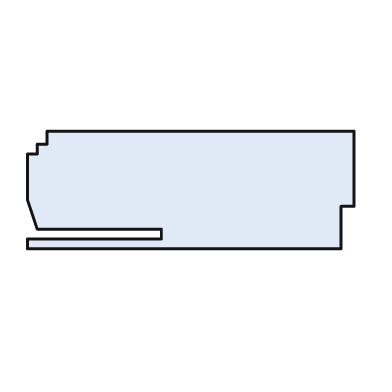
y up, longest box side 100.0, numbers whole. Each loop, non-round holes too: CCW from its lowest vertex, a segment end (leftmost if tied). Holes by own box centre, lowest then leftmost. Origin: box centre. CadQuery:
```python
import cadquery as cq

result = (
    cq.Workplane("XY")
    .moveTo(-50.0, -18.0)
    .lineTo(46.0, -18.0)
    .lineTo(46.0, -5.0)
    .lineTo(50.0, -5.0)
    .lineTo(50.0, 18.0)
    .lineTo(-44.0, 18.0)
    .lineTo(-44.0, 14.0)
    .lineTo(-47.0, 14.0)
    .lineTo(-47.0, 11.0)
    .lineTo(-50.0, 11.0)
    .lineTo(-50.0, -3.0)
    .lineTo(-47.0, -12.0)
    .lineTo(-9.0, -12.0)
    .lineTo(-9.0, -15.0)
    .lineTo(-50.0, -15.0)
    .close()
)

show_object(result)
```